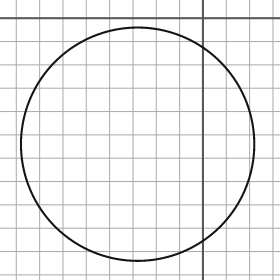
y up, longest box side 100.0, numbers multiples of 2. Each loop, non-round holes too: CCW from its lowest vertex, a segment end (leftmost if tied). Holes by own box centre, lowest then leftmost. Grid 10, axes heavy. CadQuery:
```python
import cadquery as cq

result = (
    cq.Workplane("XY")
    .moveTo(-28.0, -54.0)
    .circle(50.0)
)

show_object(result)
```